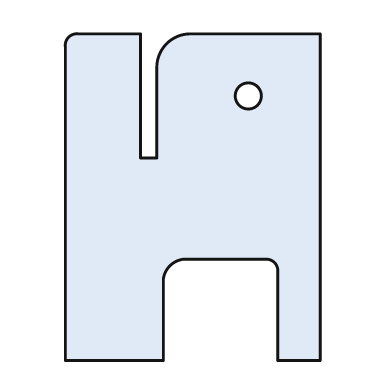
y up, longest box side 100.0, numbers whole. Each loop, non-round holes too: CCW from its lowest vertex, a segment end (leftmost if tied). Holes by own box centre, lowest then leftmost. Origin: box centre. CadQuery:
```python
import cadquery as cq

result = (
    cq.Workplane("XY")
    .moveTo(-39.0, -50.0)
    .lineTo(-9.0, -50.0)
    .lineTo(-9.0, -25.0)
    .threePointArc((-7.0, -21.0), (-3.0, -19.0))
    .lineTo(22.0, -19.0)
    .threePointArc((25.0, -20.0), (26.0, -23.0))
    .lineTo(26.0, -50.0)
    .lineTo(39.0, -50.0)
    .lineTo(39.0, 50.0)
    .lineTo(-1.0, 50.0)
    .threePointArc((-8.0, 47.0), (-11.0, 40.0))
    .lineTo(-11.0, 12.0)
    .lineTo(-16.0, 12.0)
    .lineTo(-16.0, 50.0)
    .lineTo(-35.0, 50.0)
    .threePointArc((-38.0, 49.0), (-39.0, 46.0))
    .close()
    .moveTo(17.0, 31.0)
    .circle(4.0)
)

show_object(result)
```